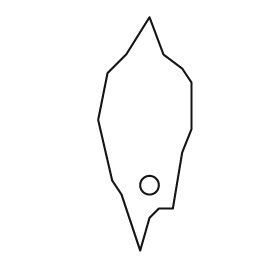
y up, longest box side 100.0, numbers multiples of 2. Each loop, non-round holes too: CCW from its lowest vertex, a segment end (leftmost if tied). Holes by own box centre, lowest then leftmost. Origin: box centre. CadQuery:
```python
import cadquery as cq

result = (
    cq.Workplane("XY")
    .moveTo(-2.0, -50.0)
    .lineTo(2.0, -36.0)
    .lineTo(6.0, -32.0)
    .lineTo(12.0, -32.0)
    .lineTo(16.0, -8.0)
    .lineTo(20.0, 2.0)
    .lineTo(20.0, 22.0)
    .lineTo(16.0, 28.0)
    .lineTo(8.0, 34.0)
    .lineTo(2.0, 50.0)
    .lineTo(-8.0, 34.0)
    .lineTo(-16.0, 26.0)
    .lineTo(-20.0, 6.0)
    .lineTo(-14.0, -20.0)
    .lineTo(-10.0, -26.0)
    .close()
    .moveTo(2.0, -22.0)
    .circle(4.0)
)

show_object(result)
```